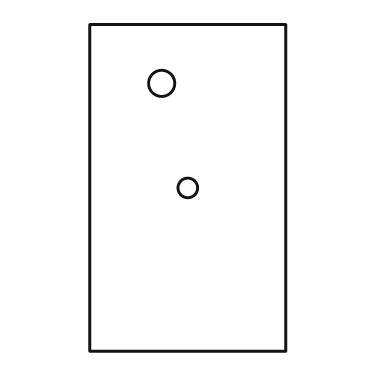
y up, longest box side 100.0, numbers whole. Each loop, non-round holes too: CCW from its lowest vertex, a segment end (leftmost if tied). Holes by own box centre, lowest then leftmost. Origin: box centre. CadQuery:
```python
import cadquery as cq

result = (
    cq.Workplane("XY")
    .moveTo(-30.0, -50.0)
    .lineTo(30.0, -50.0)
    .lineTo(30.0, 50.0)
    .lineTo(-30.0, 50.0)
    .close()
    .moveTo(0.0, 0.0)
    .circle(3.0)
    .moveTo(-8.0, 32.0)
    .circle(4.0)
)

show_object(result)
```